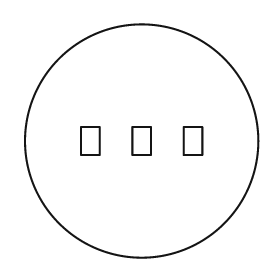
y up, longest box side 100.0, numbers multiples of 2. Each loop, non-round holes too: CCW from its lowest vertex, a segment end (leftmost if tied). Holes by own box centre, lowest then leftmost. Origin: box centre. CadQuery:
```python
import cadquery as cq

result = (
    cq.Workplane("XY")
    .moveTo(0.0, 0.0)
    .circle(50.0)
    .moveTo(-26.0, -6.0)
    .lineTo(-18.0, -6.0)
    .lineTo(-18.0, 6.0)
    .lineTo(-26.0, 6.0)
    .close()
    .moveTo(-4.0, -6.0)
    .lineTo(4.0, -6.0)
    .lineTo(4.0, 6.0)
    .lineTo(-4.0, 6.0)
    .close()
    .moveTo(18.0, -6.0)
    .lineTo(26.0, -6.0)
    .lineTo(26.0, 6.0)
    .lineTo(18.0, 6.0)
    .close()
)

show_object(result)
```